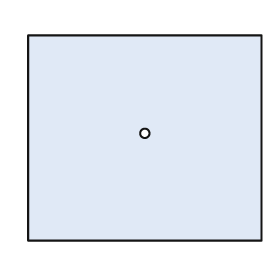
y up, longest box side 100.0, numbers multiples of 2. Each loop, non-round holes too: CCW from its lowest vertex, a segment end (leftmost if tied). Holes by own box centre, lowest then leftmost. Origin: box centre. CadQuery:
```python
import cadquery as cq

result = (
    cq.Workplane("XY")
    .moveTo(-50.0, -44.0)
    .lineTo(50.0, -44.0)
    .lineTo(50.0, 44.0)
    .lineTo(-50.0, 44.0)
    .close()
    .moveTo(0.0, 2.0)
    .circle(2.0)
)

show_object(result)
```